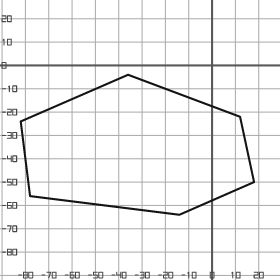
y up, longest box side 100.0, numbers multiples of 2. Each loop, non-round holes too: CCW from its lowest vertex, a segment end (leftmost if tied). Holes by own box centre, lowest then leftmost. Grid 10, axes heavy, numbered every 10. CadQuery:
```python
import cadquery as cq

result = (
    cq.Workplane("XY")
    .moveTo(-14.0, -64.0)
    .lineTo(18.0, -50.0)
    .lineTo(12.0, -22.0)
    .lineTo(-36.0, -4.0)
    .lineTo(-82.0, -24.0)
    .lineTo(-78.0, -56.0)
    .close()
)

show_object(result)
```